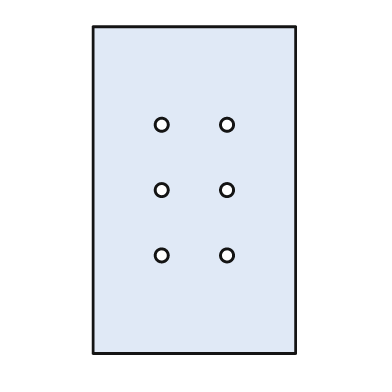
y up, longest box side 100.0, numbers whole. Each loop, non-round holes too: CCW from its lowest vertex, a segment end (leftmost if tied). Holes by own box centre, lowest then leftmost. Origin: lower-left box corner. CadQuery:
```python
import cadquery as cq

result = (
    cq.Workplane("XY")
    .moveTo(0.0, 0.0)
    .lineTo(62.0, 0.0)
    .lineTo(62.0, 100.0)
    .lineTo(0.0, 100.0)
    .close()
    .moveTo(21.0, 30.0)
    .circle(2.0)
    .moveTo(41.0, 30.0)
    .circle(2.0)
    .moveTo(21.0, 50.0)
    .circle(2.0)
    .moveTo(41.0, 50.0)
    .circle(2.0)
    .moveTo(21.0, 70.0)
    .circle(2.0)
    .moveTo(41.0, 70.0)
    .circle(2.0)
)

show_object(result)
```